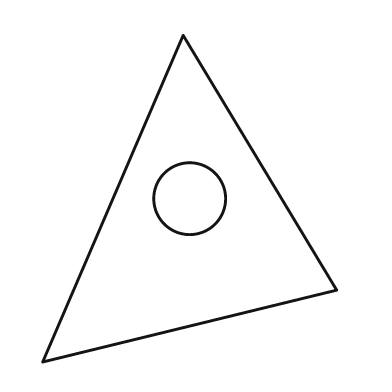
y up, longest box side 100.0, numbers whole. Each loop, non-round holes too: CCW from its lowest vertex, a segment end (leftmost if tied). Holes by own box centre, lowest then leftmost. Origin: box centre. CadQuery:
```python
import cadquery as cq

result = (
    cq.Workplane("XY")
    .moveTo(-45.0, -50.0)
    .lineTo(45.0, -28.0)
    .lineTo(-2.0, 50.0)
    .close()
    .moveTo(0.0, 0.0)
    .circle(11.0)
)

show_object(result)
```